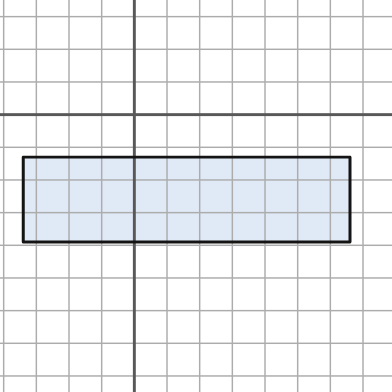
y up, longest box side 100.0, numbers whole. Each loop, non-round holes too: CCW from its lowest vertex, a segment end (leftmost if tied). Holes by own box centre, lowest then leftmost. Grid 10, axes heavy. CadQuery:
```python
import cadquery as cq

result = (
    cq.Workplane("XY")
    .moveTo(-34.0, -39.0)
    .lineTo(66.0, -39.0)
    .lineTo(66.0, -13.0)
    .lineTo(-34.0, -13.0)
    .close()
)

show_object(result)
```